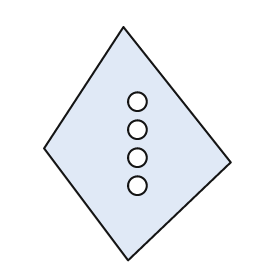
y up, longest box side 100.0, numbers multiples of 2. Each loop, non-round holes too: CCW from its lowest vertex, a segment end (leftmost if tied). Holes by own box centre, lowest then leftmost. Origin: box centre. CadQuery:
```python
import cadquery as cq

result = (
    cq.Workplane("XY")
    .moveTo(-4.0, -50.0)
    .lineTo(40.0, -8.0)
    .lineTo(-6.0, 50.0)
    .lineTo(-40.0, -2.0)
    .close()
    .moveTo(0.0, -18.0)
    .circle(4.0)
    .moveTo(0.0, -6.0)
    .circle(4.0)
    .moveTo(0.0, 6.0)
    .circle(4.0)
    .moveTo(0.0, 18.0)
    .circle(4.0)
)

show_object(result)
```